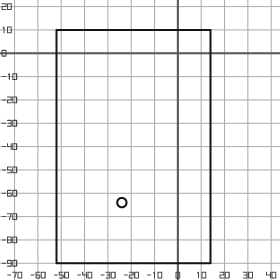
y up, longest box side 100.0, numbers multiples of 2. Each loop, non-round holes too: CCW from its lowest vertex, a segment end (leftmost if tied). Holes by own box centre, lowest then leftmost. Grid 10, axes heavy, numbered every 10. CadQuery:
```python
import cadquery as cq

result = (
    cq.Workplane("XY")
    .moveTo(-52.0, -90.0)
    .lineTo(14.0, -90.0)
    .lineTo(14.0, 10.0)
    .lineTo(-52.0, 10.0)
    .close()
    .moveTo(-24.0, -64.0)
    .circle(2.0)
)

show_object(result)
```